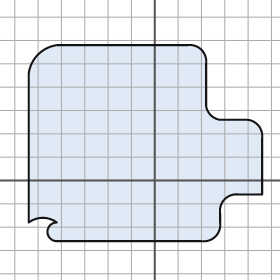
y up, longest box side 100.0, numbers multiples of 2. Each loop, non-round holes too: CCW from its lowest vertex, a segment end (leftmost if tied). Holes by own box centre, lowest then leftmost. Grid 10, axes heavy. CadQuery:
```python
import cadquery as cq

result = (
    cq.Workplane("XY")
    .moveTo(-42.0, -26.0)
    .lineTo(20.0, -26.0)
    .threePointArc((26.0, -24.0), (28.0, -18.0))
    .lineTo(28.0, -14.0)
    .threePointArc((30.0, -8.0), (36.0, -6.0))
    .lineTo(46.0, -6.0)
    .lineTo(46.0, 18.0)
    .threePointArc((44.0, 24.0), (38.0, 26.0))
    .lineTo(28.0, 26.0)
    .threePointArc((24.0, 28.0), (22.0, 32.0))
    .lineTo(22.0, 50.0)
    .threePointArc((20.0, 56.0), (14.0, 58.0))
    .lineTo(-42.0, 58.0)
    .threePointArc((-50.0, 54.0), (-54.0, 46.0))
    .lineTo(-54.0, -18.0)
    .threePointArc((-48.0, -16.0), (-42.0, -18.0))
    .threePointArc((-46.0, -22.0), (-42.0, -26.0))
    .close()
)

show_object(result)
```